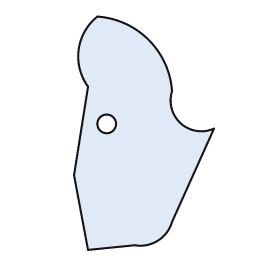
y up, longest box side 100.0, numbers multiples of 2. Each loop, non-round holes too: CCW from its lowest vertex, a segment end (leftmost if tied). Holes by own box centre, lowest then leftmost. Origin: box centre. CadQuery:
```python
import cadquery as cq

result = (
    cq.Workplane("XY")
    .moveTo(-24.0, -50.0)
    .lineTo(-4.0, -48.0)
    .threePointArc((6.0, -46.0), (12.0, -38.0))
    .lineTo(30.0, 2.0)
    .threePointArc((16.0, 4.0), (12.0, 18.0))
    .threePointArc((2.0, 40.0), (-20.0, 50.0))
    .threePointArc((-28.0, 36.0), (-24.0, 20.0))
    .lineTo(-30.0, -18.0)
    .close()
    .moveTo(-16.0, 4.0)
    .circle(4.0)
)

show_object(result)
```